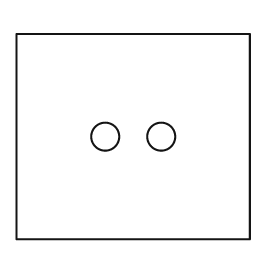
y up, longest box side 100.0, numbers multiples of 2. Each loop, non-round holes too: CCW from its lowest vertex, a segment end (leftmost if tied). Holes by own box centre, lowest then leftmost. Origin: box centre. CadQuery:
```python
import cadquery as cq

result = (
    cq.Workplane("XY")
    .moveTo(-50.0, -44.0)
    .lineTo(50.0, -44.0)
    .lineTo(50.0, 44.0)
    .lineTo(-50.0, 44.0)
    .close()
    .moveTo(-12.0, 0.0)
    .circle(6.0)
    .moveTo(12.0, 0.0)
    .circle(6.0)
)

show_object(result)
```